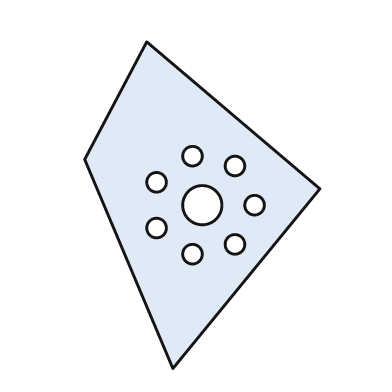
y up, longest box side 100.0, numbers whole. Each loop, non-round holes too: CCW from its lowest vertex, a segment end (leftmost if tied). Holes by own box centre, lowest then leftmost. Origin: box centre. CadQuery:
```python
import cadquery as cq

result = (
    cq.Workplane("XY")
    .moveTo(-9.0, -50.0)
    .lineTo(36.0, 5.0)
    .lineTo(-17.0, 50.0)
    .lineTo(-36.0, 14.0)
    .close()
    .moveTo(-3.0, -15.0)
    .circle(3.0)
    .moveTo(10.0, -12.0)
    .circle(3.0)
    .moveTo(-14.0, -7.0)
    .circle(3.0)
    .moveTo(0.0, 0.0)
    .circle(6.0)
    .moveTo(16.0, 0.0)
    .circle(3.0)
    .moveTo(-14.0, 7.0)
    .circle(3.0)
    .moveTo(10.0, 12.0)
    .circle(3.0)
    .moveTo(-3.0, 15.0)
    .circle(3.0)
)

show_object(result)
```